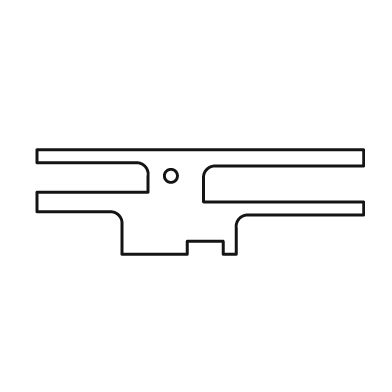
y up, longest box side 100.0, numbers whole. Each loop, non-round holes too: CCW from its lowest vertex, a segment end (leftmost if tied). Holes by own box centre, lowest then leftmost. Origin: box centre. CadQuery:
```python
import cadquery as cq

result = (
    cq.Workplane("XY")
    .moveTo(-24.0, -16.0)
    .lineTo(-4.0, -16.0)
    .lineTo(-4.0, -12.0)
    .lineTo(7.0, -12.0)
    .lineTo(7.0, -16.0)
    .lineTo(11.0, -16.0)
    .lineTo(11.0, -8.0)
    .threePointArc((12.0, -5.0), (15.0, -4.0))
    .lineTo(50.0, -4.0)
    .lineTo(50.0, 0.0)
    .lineTo(1.0, 0.0)
    .lineTo(1.0, 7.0)
    .threePointArc((2.0, 10.0), (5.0, 11.0))
    .lineTo(50.0, 11.0)
    .lineTo(50.0, 16.0)
    .lineTo(-50.0, 16.0)
    .lineTo(-50.0, 12.0)
    .lineTo(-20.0, 12.0)
    .threePointArc((-17.0, 11.0), (-16.0, 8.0))
    .lineTo(-16.0, 3.0)
    .lineTo(-50.0, 3.0)
    .lineTo(-50.0, -3.0)
    .lineTo(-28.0, -3.0)
    .threePointArc((-25.0, -4.0), (-24.0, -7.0))
    .close()
    .moveTo(-9.0, 8.0)
    .circle(2.0)
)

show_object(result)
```